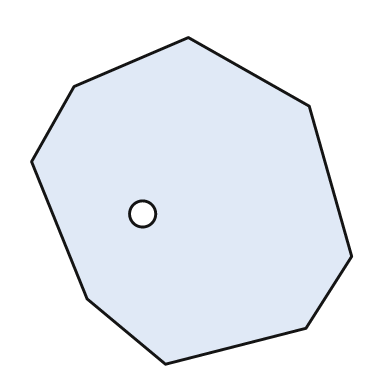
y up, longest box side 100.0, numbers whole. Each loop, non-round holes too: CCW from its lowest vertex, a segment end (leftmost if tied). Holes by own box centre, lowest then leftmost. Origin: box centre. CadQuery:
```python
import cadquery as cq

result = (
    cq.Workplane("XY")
    .moveTo(-8.0, -50.0)
    .lineTo(35.0, -39.0)
    .lineTo(49.0, -17.0)
    .lineTo(36.0, 29.0)
    .lineTo(-1.0, 50.0)
    .lineTo(-36.0, 35.0)
    .lineTo(-49.0, 12.0)
    .lineTo(-32.0, -30.0)
    .close()
    .moveTo(-15.0, -4.0)
    .circle(4.0)
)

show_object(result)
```